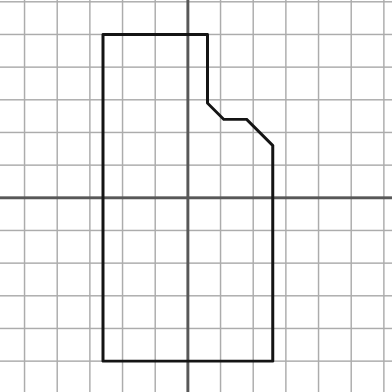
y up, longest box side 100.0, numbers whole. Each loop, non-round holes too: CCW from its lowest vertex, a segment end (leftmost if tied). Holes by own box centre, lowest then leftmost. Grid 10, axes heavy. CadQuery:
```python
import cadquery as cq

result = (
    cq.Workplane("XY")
    .moveTo(-26.0, -50.0)
    .lineTo(26.0, -50.0)
    .lineTo(26.0, 16.0)
    .lineTo(18.0, 24.0)
    .lineTo(11.0, 24.0)
    .lineTo(6.0, 29.0)
    .lineTo(6.0, 50.0)
    .lineTo(-26.0, 50.0)
    .close()
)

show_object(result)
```